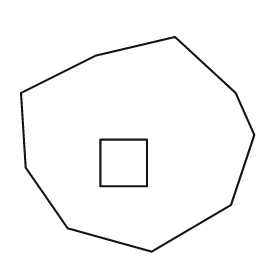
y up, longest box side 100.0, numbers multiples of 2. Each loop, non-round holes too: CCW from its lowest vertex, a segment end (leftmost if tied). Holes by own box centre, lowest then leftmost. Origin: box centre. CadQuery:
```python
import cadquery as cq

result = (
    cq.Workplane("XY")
    .moveTo(6.0, -46.0)
    .lineTo(40.0, -26.0)
    .lineTo(50.0, 4.0)
    .lineTo(42.0, 22.0)
    .lineTo(16.0, 46.0)
    .lineTo(-18.0, 38.0)
    .lineTo(-50.0, 22.0)
    .lineTo(-48.0, -10.0)
    .lineTo(-30.0, -36.0)
    .close()
    .moveTo(-16.0, -18.0)
    .lineTo(4.0, -18.0)
    .lineTo(4.0, 2.0)
    .lineTo(-16.0, 2.0)
    .close()
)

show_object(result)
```